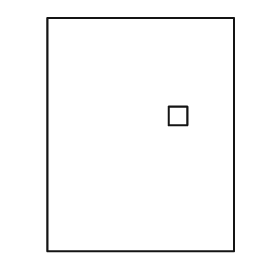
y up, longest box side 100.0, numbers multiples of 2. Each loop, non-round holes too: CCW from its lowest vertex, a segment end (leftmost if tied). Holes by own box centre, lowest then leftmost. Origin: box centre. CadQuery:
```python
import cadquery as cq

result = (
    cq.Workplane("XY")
    .moveTo(-40.0, -50.0)
    .lineTo(40.0, -50.0)
    .lineTo(40.0, 50.0)
    .lineTo(-40.0, 50.0)
    .close()
    .moveTo(12.0, 4.0)
    .lineTo(20.0, 4.0)
    .lineTo(20.0, 12.0)
    .lineTo(12.0, 12.0)
    .close()
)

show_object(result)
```